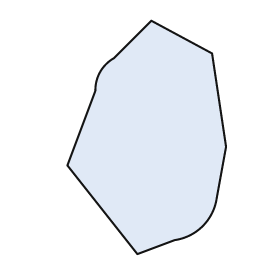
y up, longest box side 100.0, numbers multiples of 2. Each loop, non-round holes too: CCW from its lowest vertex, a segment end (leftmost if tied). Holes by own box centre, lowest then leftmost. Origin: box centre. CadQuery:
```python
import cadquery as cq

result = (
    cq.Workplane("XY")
    .moveTo(-4.0, -50.0)
    .lineTo(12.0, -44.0)
    .threePointArc((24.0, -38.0), (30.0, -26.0))
    .lineTo(34.0, -4.0)
    .lineTo(28.0, 36.0)
    .lineTo(2.0, 50.0)
    .lineTo(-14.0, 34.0)
    .threePointArc((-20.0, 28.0), (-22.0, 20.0))
    .lineTo(-34.0, -12.0)
    .close()
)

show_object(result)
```